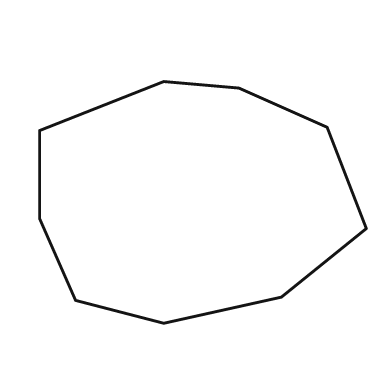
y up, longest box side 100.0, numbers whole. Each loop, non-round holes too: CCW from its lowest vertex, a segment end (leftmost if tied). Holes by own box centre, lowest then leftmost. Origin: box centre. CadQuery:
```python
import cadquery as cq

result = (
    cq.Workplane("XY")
    .moveTo(-12.0, -37.0)
    .lineTo(24.0, -29.0)
    .lineTo(50.0, -8.0)
    .lineTo(38.0, 23.0)
    .lineTo(11.0, 35.0)
    .lineTo(-12.0, 37.0)
    .lineTo(-50.0, 22.0)
    .lineTo(-50.0, -5.0)
    .lineTo(-39.0, -30.0)
    .close()
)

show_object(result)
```